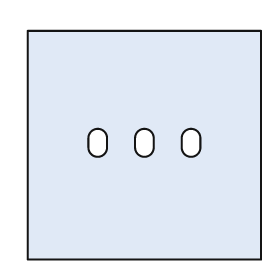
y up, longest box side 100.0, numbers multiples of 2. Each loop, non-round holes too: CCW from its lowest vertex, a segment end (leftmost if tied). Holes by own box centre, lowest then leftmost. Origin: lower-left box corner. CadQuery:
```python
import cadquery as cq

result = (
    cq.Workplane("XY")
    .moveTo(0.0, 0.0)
    .lineTo(100.0, 0.0)
    .lineTo(100.0, 98.0)
    .lineTo(0.0, 98.0)
    .close()
    .moveTo(26.0, 48.0)
    .threePointArc((30.0, 44.0), (34.0, 48.0))
    .lineTo(34.0, 52.0)
    .threePointArc((30.0, 56.0), (26.0, 52.0))
    .close()
    .moveTo(46.0, 48.0)
    .threePointArc((50.0, 44.0), (54.0, 48.0))
    .lineTo(54.0, 52.0)
    .threePointArc((50.0, 56.0), (46.0, 52.0))
    .close()
    .moveTo(66.0, 48.0)
    .threePointArc((70.0, 44.0), (74.0, 48.0))
    .lineTo(74.0, 52.0)
    .threePointArc((70.0, 56.0), (66.0, 52.0))
    .close()
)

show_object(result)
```